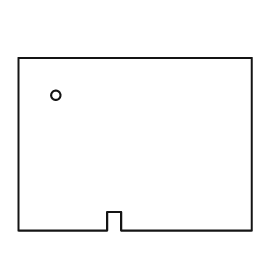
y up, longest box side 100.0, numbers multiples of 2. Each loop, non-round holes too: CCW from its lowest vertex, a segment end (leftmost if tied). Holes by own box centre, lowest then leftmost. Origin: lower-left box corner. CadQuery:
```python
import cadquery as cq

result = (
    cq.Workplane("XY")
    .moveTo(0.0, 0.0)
    .lineTo(38.0, 0.0)
    .lineTo(38.0, 8.0)
    .lineTo(44.0, 8.0)
    .lineTo(44.0, 0.0)
    .lineTo(100.0, 0.0)
    .lineTo(100.0, 74.0)
    .lineTo(0.0, 74.0)
    .close()
    .moveTo(16.0, 58.0)
    .circle(2.0)
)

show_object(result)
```